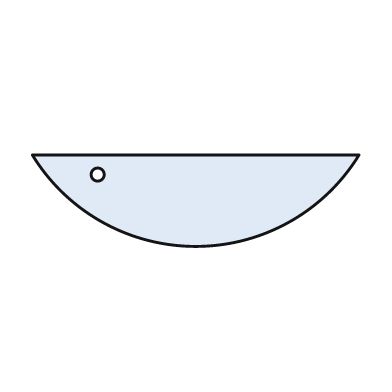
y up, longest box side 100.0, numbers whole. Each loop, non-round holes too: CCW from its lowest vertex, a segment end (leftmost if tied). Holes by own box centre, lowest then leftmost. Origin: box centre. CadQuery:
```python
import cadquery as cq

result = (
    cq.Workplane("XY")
    .moveTo(-50.0, 14.0)
    .threePointArc((0.0, -14.0), (50.0, 14.0))
    .close()
    .moveTo(-30.0, 8.0)
    .circle(2.0)
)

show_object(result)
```